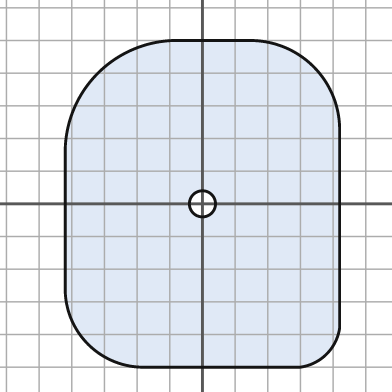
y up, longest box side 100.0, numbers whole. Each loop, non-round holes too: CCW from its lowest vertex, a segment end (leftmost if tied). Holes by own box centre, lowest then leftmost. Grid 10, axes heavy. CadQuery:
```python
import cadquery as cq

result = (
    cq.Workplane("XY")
    .moveTo(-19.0, -50.0)
    .lineTo(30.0, -50.0)
    .threePointArc((38.0, -46.0), (42.0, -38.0))
    .lineTo(42.0, 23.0)
    .threePointArc((34.0, 42.0), (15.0, 50.0))
    .lineTo(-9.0, 50.0)
    .threePointArc((-32.0, 40.0), (-42.0, 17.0))
    .lineTo(-42.0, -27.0)
    .threePointArc((-35.0, -43.0), (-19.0, -50.0))
    .close()
    .moveTo(0.0, 0.0)
    .circle(4.0)
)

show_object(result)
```